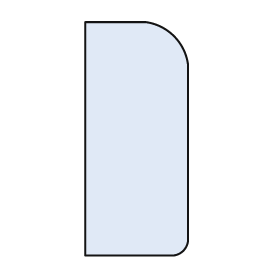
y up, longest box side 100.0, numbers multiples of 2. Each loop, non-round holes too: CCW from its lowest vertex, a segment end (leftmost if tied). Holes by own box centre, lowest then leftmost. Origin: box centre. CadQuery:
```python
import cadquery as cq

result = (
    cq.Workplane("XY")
    .moveTo(-22.0, -50.0)
    .lineTo(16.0, -50.0)
    .threePointArc((20.0, -48.0), (22.0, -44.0))
    .lineTo(22.0, 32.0)
    .threePointArc((16.0, 44.0), (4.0, 50.0))
    .lineTo(-22.0, 50.0)
    .close()
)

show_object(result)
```